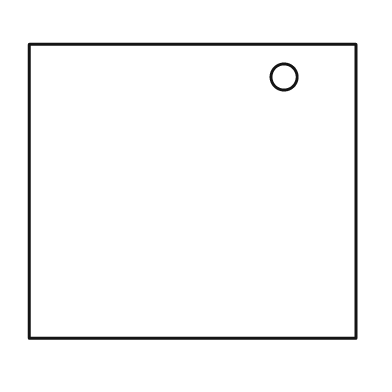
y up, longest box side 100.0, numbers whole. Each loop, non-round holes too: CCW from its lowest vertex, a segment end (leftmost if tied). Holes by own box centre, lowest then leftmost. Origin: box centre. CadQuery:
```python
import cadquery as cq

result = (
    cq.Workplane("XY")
    .moveTo(-50.0, -45.0)
    .lineTo(50.0, -45.0)
    .lineTo(50.0, 45.0)
    .lineTo(-50.0, 45.0)
    .close()
    .moveTo(28.0, 35.0)
    .circle(4.0)
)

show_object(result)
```